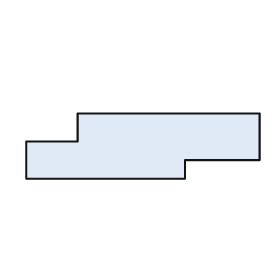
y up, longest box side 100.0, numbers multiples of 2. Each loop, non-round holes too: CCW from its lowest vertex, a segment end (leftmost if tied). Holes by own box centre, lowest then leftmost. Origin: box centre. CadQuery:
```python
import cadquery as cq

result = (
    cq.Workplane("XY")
    .moveTo(-50.0, -14.0)
    .lineTo(18.0, -14.0)
    .lineTo(18.0, -6.0)
    .lineTo(50.0, -6.0)
    .lineTo(50.0, 14.0)
    .lineTo(-28.0, 14.0)
    .lineTo(-28.0, 2.0)
    .lineTo(-50.0, 2.0)
    .close()
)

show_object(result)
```